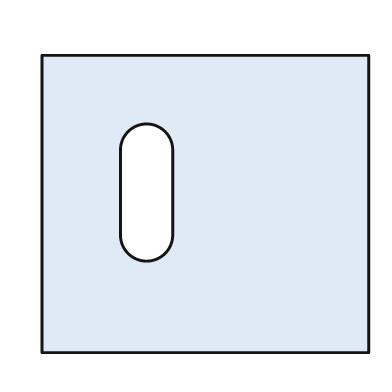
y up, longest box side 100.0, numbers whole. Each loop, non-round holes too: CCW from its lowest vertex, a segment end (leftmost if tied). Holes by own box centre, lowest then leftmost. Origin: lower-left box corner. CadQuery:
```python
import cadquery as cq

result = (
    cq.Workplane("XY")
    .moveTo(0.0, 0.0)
    .lineTo(100.0, 0.0)
    .lineTo(100.0, 91.0)
    .lineTo(0.0, 91.0)
    .close()
    .moveTo(24.0, 36.0)
    .threePointArc((32.0, 28.0), (40.0, 36.0))
    .lineTo(40.0, 62.0)
    .threePointArc((32.0, 70.0), (24.0, 62.0))
    .close()
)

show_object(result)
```